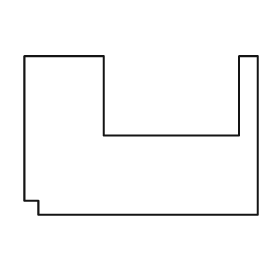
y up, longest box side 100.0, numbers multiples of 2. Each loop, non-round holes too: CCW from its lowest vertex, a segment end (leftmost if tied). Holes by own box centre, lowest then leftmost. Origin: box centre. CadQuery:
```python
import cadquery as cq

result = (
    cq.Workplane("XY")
    .moveTo(-44.0, -34.0)
    .lineTo(50.0, -34.0)
    .lineTo(50.0, 34.0)
    .lineTo(42.0, 34.0)
    .lineTo(42.0, 0.0)
    .lineTo(-16.0, 0.0)
    .lineTo(-16.0, 34.0)
    .lineTo(-50.0, 34.0)
    .lineTo(-50.0, -28.0)
    .lineTo(-44.0, -28.0)
    .close()
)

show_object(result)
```